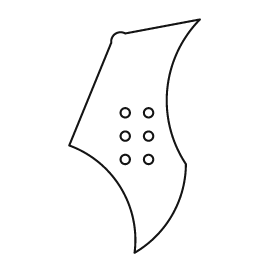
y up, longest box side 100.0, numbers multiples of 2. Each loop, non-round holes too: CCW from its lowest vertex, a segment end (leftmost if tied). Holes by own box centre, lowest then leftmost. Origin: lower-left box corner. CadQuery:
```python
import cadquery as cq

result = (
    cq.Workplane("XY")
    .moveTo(28.0, 0.0)
    .threePointArc((44.0, 16.0), (50.0, 38.0))
    .threePointArc((42.0, 70.0), (56.0, 100.0))
    .lineTo(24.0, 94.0)
    .threePointArc((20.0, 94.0), (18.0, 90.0))
    .lineTo(0.0, 46.0)
    .threePointArc((22.0, 28.0), (28.0, 0.0))
    .close()
    .moveTo(24.0, 40.0)
    .circle(2.0)
    .moveTo(34.0, 40.0)
    .circle(2.0)
    .moveTo(24.0, 50.0)
    .circle(2.0)
    .moveTo(34.0, 50.0)
    .circle(2.0)
    .moveTo(24.0, 60.0)
    .circle(2.0)
    .moveTo(34.0, 60.0)
    .circle(2.0)
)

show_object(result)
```